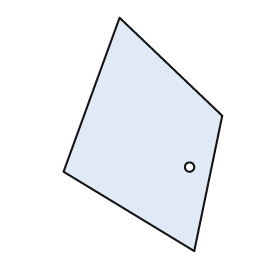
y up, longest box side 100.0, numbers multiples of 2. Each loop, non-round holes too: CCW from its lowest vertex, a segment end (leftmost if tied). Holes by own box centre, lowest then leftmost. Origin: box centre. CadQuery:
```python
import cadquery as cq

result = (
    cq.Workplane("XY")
    .moveTo(22.0, -50.0)
    .lineTo(34.0, 8.0)
    .lineTo(-10.0, 50.0)
    .lineTo(-34.0, -16.0)
    .close()
    .moveTo(20.0, -14.0)
    .circle(2.0)
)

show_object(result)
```